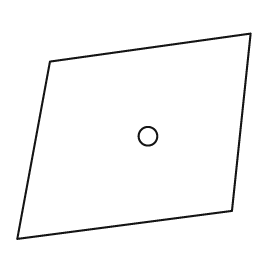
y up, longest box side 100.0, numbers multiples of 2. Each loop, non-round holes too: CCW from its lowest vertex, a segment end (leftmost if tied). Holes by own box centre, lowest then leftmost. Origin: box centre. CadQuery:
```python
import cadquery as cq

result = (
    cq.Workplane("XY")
    .moveTo(-50.0, -44.0)
    .lineTo(42.0, -32.0)
    .lineTo(50.0, 44.0)
    .lineTo(-36.0, 32.0)
    .close()
    .moveTo(6.0, 0.0)
    .circle(4.0)
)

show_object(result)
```